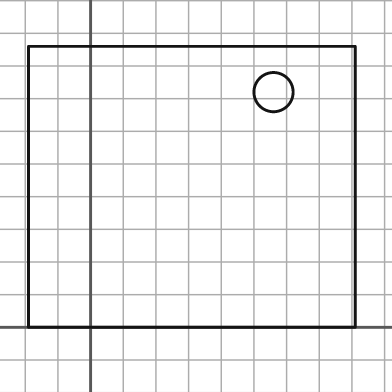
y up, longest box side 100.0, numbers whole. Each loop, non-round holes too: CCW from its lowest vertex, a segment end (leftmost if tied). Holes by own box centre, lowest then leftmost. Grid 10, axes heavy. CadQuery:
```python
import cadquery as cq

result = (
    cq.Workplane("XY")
    .moveTo(-19.0, 0.0)
    .lineTo(81.0, 0.0)
    .lineTo(81.0, 86.0)
    .lineTo(-19.0, 86.0)
    .close()
    .moveTo(56.0, 72.0)
    .circle(6.0)
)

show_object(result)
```